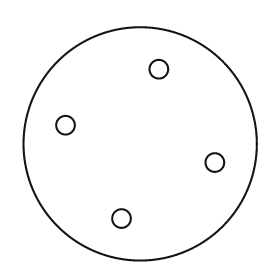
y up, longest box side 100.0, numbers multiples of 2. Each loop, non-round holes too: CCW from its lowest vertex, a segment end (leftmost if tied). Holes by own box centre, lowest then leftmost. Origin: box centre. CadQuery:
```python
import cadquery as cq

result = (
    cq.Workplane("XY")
    .moveTo(0.0, 0.0)
    .circle(50.0)
    .moveTo(-8.0, -32.0)
    .circle(4.0)
    .moveTo(32.0, -8.0)
    .circle(4.0)
    .moveTo(-32.0, 8.0)
    .circle(4.0)
    .moveTo(8.0, 32.0)
    .circle(4.0)
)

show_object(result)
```